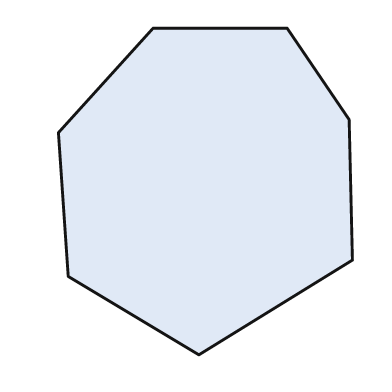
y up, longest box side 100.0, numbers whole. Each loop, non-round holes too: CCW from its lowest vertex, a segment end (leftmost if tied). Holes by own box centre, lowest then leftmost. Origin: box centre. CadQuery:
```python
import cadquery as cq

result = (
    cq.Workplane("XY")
    .moveTo(-2.0, -50.0)
    .lineTo(45.0, -21.0)
    .lineTo(44.0, 22.0)
    .lineTo(25.0, 50.0)
    .lineTo(-16.0, 50.0)
    .lineTo(-45.0, 18.0)
    .lineTo(-42.0, -26.0)
    .close()
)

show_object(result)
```